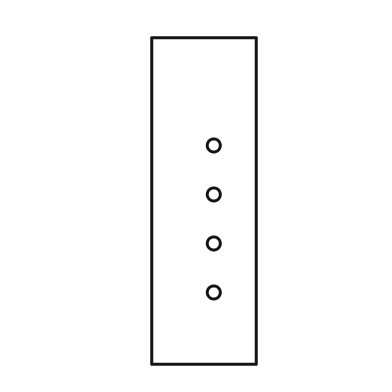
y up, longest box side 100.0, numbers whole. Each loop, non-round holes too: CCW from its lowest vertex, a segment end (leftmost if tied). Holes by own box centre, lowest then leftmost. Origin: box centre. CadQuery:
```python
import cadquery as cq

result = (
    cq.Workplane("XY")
    .moveTo(-16.0, -50.0)
    .lineTo(16.0, -50.0)
    .lineTo(16.0, 50.0)
    .lineTo(-16.0, 50.0)
    .close()
    .moveTo(3.0, -28.0)
    .circle(2.0)
    .moveTo(3.0, -13.0)
    .circle(2.0)
    .moveTo(3.0, 2.0)
    .circle(2.0)
    .moveTo(3.0, 17.0)
    .circle(2.0)
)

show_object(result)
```